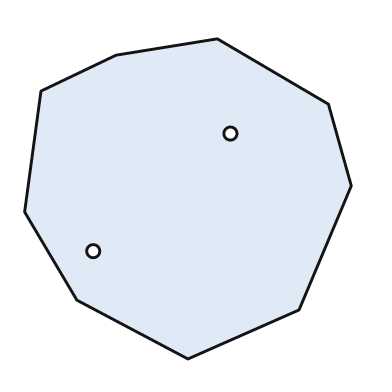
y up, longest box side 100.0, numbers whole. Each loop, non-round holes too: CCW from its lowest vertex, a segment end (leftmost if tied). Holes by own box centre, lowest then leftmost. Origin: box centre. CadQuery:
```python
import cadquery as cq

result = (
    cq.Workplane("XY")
    .moveTo(0.0, -49.0)
    .lineTo(34.0, -34.0)
    .lineTo(50.0, 4.0)
    .lineTo(43.0, 29.0)
    .lineTo(9.0, 49.0)
    .lineTo(-22.0, 44.0)
    .lineTo(-45.0, 33.0)
    .lineTo(-50.0, -4.0)
    .lineTo(-34.0, -31.0)
    .close()
    .moveTo(-29.0, -16.0)
    .circle(2.0)
    .moveTo(13.0, 20.0)
    .circle(2.0)
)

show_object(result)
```